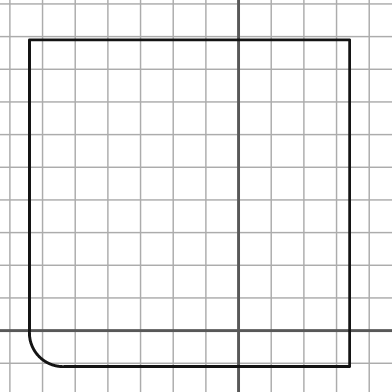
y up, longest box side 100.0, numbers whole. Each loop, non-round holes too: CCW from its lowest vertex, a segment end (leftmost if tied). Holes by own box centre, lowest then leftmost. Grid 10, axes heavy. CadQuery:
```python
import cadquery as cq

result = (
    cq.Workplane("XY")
    .moveTo(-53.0, -11.0)
    .lineTo(34.0, -11.0)
    .lineTo(34.0, 89.0)
    .lineTo(-64.0, 89.0)
    .lineTo(-64.0, 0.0)
    .threePointArc((-61.0, -8.0), (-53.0, -11.0))
    .close()
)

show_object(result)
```